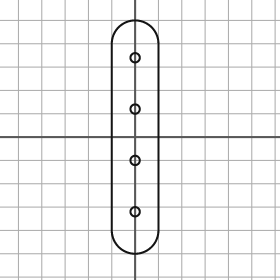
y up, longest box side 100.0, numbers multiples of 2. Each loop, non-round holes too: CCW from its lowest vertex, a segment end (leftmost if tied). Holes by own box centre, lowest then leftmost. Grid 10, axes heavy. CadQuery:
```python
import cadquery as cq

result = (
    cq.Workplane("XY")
    .moveTo(-10.0, -40.0)
    .threePointArc((0.0, -50.0), (10.0, -40.0))
    .lineTo(10.0, 40.0)
    .threePointArc((0.0, 50.0), (-10.0, 40.0))
    .close()
    .moveTo(0.0, -32.0)
    .circle(2.0)
    .moveTo(0.0, -10.0)
    .circle(2.0)
    .moveTo(0.0, 12.0)
    .circle(2.0)
    .moveTo(0.0, 34.0)
    .circle(2.0)
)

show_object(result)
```